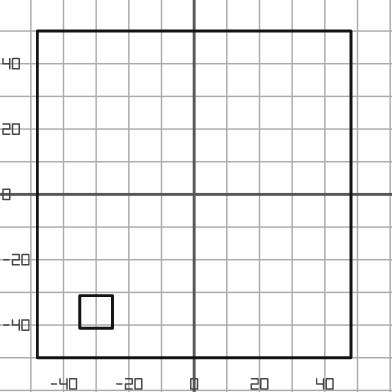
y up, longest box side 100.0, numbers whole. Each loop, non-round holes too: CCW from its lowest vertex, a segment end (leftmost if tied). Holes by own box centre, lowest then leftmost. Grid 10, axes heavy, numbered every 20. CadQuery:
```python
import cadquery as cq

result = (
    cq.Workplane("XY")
    .moveTo(-48.0, -50.0)
    .lineTo(48.0, -50.0)
    .lineTo(48.0, 50.0)
    .lineTo(-48.0, 50.0)
    .close()
    .moveTo(-35.0, -41.0)
    .lineTo(-25.0, -41.0)
    .lineTo(-25.0, -31.0)
    .lineTo(-35.0, -31.0)
    .close()
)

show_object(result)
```